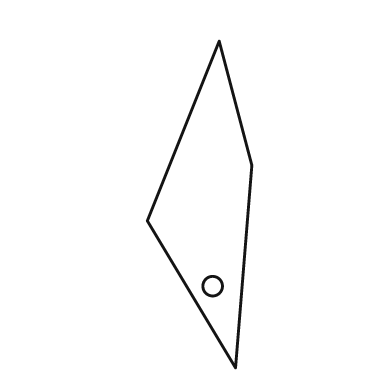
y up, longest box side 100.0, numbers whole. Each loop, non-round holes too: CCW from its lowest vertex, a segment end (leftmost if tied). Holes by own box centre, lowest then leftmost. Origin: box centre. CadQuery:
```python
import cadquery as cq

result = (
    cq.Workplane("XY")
    .moveTo(11.0, -50.0)
    .lineTo(16.0, 12.0)
    .lineTo(6.0, 50.0)
    .lineTo(-16.0, -5.0)
    .close()
    .moveTo(4.0, -25.0)
    .circle(3.0)
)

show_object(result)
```